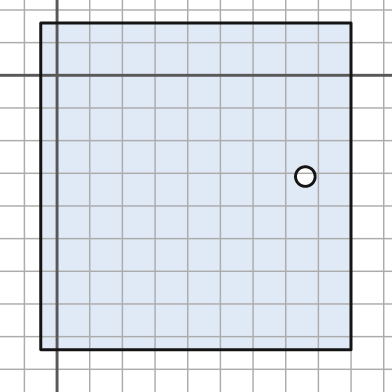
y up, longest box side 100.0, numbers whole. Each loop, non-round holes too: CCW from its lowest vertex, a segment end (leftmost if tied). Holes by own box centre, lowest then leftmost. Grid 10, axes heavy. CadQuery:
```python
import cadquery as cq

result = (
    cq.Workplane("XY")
    .moveTo(-5.0, -84.0)
    .lineTo(90.0, -84.0)
    .lineTo(90.0, 16.0)
    .lineTo(-5.0, 16.0)
    .close()
    .moveTo(76.0, -31.0)
    .circle(3.0)
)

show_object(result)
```